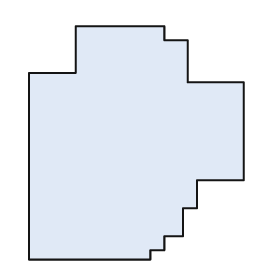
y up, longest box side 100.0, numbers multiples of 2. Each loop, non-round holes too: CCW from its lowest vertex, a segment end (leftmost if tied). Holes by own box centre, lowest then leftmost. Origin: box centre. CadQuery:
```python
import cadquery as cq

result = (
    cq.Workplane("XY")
    .moveTo(-46.0, -50.0)
    .lineTo(6.0, -50.0)
    .lineTo(6.0, -46.0)
    .lineTo(12.0, -46.0)
    .lineTo(12.0, -40.0)
    .lineTo(20.0, -40.0)
    .lineTo(20.0, -28.0)
    .lineTo(26.0, -28.0)
    .lineTo(26.0, -16.0)
    .lineTo(46.0, -16.0)
    .lineTo(46.0, 26.0)
    .lineTo(22.0, 26.0)
    .lineTo(22.0, 44.0)
    .lineTo(12.0, 44.0)
    .lineTo(12.0, 50.0)
    .lineTo(-26.0, 50.0)
    .lineTo(-26.0, 30.0)
    .lineTo(-46.0, 30.0)
    .close()
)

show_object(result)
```